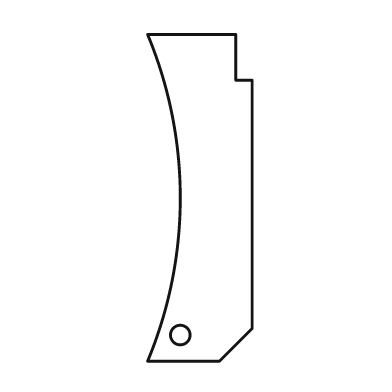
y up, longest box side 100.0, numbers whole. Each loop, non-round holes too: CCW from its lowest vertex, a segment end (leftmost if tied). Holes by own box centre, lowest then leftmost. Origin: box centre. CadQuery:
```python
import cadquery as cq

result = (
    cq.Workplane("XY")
    .moveTo(-16.0, -50.0)
    .lineTo(6.0, -50.0)
    .lineTo(16.0, -40.0)
    .lineTo(16.0, 36.0)
    .lineTo(11.0, 36.0)
    .lineTo(11.0, 50.0)
    .lineTo(-16.0, 50.0)
    .threePointArc((-6.0, 0.0), (-16.0, -50.0))
    .close()
    .moveTo(-6.0, -42.0)
    .circle(3.0)
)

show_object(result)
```